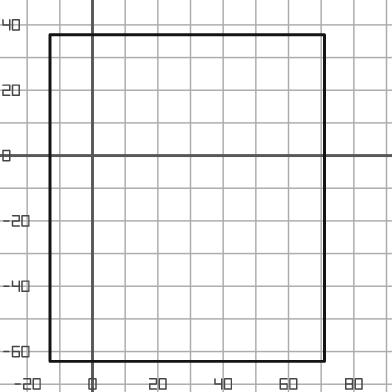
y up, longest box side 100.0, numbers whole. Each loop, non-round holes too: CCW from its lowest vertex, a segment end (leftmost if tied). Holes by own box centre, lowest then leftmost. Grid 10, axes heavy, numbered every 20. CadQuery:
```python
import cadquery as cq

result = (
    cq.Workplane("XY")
    .moveTo(-13.0, -63.0)
    .lineTo(71.0, -63.0)
    .lineTo(71.0, 37.0)
    .lineTo(-13.0, 37.0)
    .close()
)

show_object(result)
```